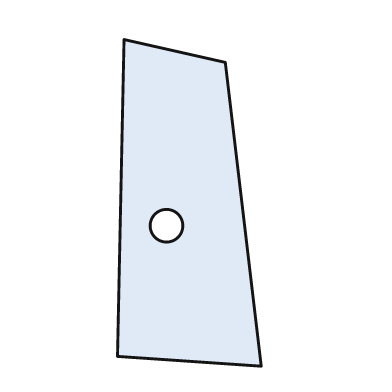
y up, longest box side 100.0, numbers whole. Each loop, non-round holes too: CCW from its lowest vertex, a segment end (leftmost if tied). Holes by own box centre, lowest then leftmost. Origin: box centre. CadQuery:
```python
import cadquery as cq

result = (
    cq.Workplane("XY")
    .moveTo(22.0, -50.0)
    .lineTo(11.0, 43.0)
    .lineTo(-20.0, 50.0)
    .lineTo(-22.0, -47.0)
    .close()
    .moveTo(-7.0, -7.0)
    .circle(5.0)
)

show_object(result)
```